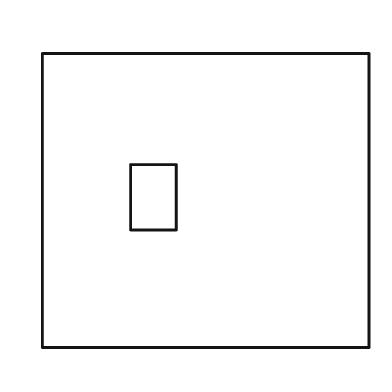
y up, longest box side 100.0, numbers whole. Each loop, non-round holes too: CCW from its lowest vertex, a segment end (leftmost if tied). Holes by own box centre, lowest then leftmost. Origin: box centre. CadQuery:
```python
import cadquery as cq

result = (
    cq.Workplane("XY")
    .moveTo(-50.0, -45.0)
    .lineTo(50.0, -45.0)
    .lineTo(50.0, 45.0)
    .lineTo(-50.0, 45.0)
    .close()
    .moveTo(-23.0, -9.0)
    .lineTo(-9.0, -9.0)
    .lineTo(-9.0, 11.0)
    .lineTo(-23.0, 11.0)
    .close()
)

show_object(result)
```